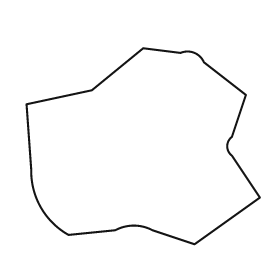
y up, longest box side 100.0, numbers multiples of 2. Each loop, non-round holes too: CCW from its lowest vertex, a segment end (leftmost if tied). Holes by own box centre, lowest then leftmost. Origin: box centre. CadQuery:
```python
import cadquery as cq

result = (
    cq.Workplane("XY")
    .moveTo(22.0, -42.0)
    .lineTo(50.0, -22.0)
    .lineTo(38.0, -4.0)
    .threePointArc((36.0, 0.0), (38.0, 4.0))
    .lineTo(44.0, 22.0)
    .lineTo(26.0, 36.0)
    .threePointArc((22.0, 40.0), (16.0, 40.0))
    .lineTo(0.0, 42.0)
    .lineTo(-22.0, 24.0)
    .lineTo(-50.0, 18.0)
    .lineTo(-48.0, -10.0)
    .threePointArc((-44.0, -26.0), (-32.0, -38.0))
    .lineTo(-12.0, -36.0)
    .threePointArc((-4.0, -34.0), (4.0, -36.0))
    .close()
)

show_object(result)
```